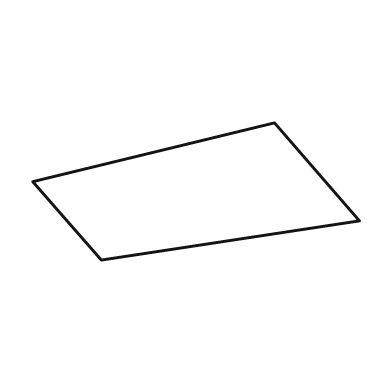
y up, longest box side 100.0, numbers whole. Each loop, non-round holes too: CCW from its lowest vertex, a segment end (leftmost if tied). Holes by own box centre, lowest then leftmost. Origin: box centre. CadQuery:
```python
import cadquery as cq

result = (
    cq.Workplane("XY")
    .moveTo(-29.0, -21.0)
    .lineTo(50.0, -9.0)
    .lineTo(24.0, 21.0)
    .lineTo(-50.0, 3.0)
    .close()
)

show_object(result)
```